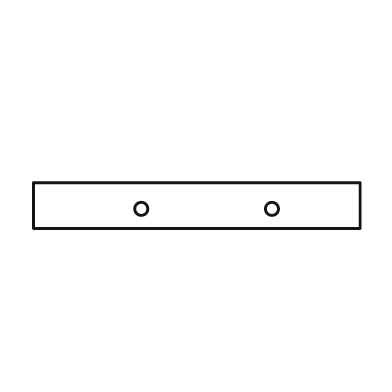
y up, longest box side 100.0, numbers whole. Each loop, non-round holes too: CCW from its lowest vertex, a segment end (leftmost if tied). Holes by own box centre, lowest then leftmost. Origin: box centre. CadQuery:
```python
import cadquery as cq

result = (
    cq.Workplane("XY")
    .moveTo(-50.0, -7.0)
    .lineTo(50.0, -7.0)
    .lineTo(50.0, 7.0)
    .lineTo(-50.0, 7.0)
    .close()
    .moveTo(-17.0, -1.0)
    .circle(2.0)
    .moveTo(23.0, -1.0)
    .circle(2.0)
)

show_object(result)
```